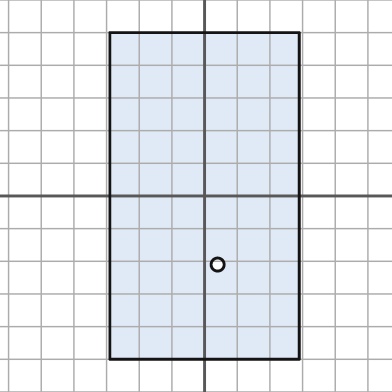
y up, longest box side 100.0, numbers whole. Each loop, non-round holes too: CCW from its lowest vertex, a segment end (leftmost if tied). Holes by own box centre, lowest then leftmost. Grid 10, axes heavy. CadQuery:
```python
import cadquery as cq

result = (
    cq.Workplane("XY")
    .moveTo(-29.0, -50.0)
    .lineTo(29.0, -50.0)
    .lineTo(29.0, 50.0)
    .lineTo(-29.0, 50.0)
    .close()
    .moveTo(4.0, -21.0)
    .circle(2.0)
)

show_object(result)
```